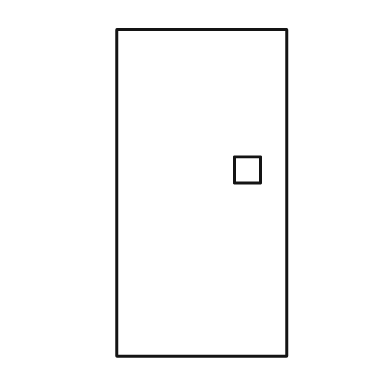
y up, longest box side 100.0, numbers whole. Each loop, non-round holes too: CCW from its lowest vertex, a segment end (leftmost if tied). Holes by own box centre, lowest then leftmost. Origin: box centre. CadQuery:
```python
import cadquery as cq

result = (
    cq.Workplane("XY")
    .moveTo(-26.0, -50.0)
    .lineTo(26.0, -50.0)
    .lineTo(26.0, 50.0)
    .lineTo(-26.0, 50.0)
    .close()
    .moveTo(10.0, 3.0)
    .lineTo(18.0, 3.0)
    .lineTo(18.0, 11.0)
    .lineTo(10.0, 11.0)
    .close()
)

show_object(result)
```